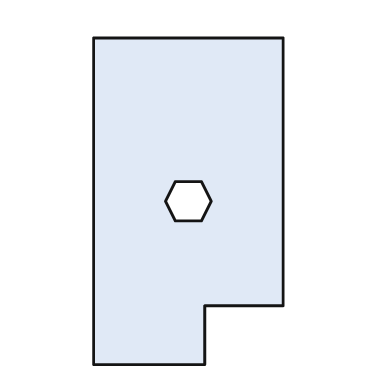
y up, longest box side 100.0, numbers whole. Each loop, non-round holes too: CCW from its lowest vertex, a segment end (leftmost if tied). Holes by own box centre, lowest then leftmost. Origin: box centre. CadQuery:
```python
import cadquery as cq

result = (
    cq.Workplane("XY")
    .moveTo(-29.0, -50.0)
    .lineTo(5.0, -50.0)
    .lineTo(5.0, -32.0)
    .lineTo(29.0, -32.0)
    .lineTo(29.0, 50.0)
    .lineTo(-29.0, 50.0)
    .close()
    .moveTo(-4.0, -6.0)
    .lineTo(4.0, -6.0)
    .lineTo(7.0, 0.0)
    .lineTo(4.0, 6.0)
    .lineTo(-4.0, 6.0)
    .lineTo(-7.0, 0.0)
    .close()
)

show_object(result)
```